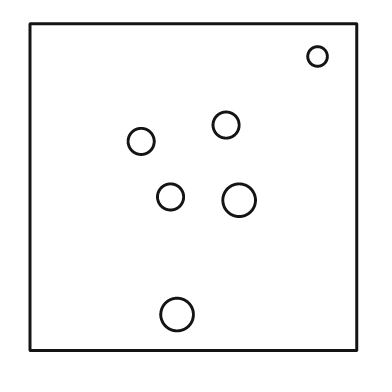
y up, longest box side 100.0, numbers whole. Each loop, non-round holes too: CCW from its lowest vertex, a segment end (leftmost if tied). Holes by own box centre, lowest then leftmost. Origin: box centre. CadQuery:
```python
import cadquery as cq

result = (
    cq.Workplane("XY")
    .moveTo(-50.0, -50.0)
    .lineTo(50.0, -50.0)
    .lineTo(50.0, 50.0)
    .lineTo(-50.0, 50.0)
    .close()
    .moveTo(-5.0, -39.0)
    .circle(5.0)
    .moveTo(14.0, -4.0)
    .circle(5.0)
    .moveTo(-7.0, -3.0)
    .circle(4.0)
    .moveTo(-16.0, 14.0)
    .circle(4.0)
    .moveTo(10.0, 19.0)
    .circle(4.0)
    .moveTo(38.0, 40.0)
    .circle(3.0)
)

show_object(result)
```